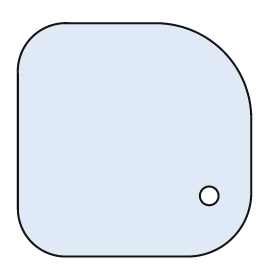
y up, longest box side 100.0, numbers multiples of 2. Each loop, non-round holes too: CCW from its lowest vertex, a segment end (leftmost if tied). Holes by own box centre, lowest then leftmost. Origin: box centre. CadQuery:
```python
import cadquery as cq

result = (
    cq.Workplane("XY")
    .moveTo(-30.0, -50.0)
    .lineTo(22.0, -50.0)
    .threePointArc((42.0, -42.0), (50.0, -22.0))
    .lineTo(50.0, 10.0)
    .threePointArc((38.0, 38.0), (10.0, 50.0))
    .lineTo(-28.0, 50.0)
    .threePointArc((-44.0, 44.0), (-50.0, 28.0))
    .lineTo(-50.0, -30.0)
    .threePointArc((-44.0, -44.0), (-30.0, -50.0))
    .close()
    .moveTo(32.0, -24.0)
    .circle(4.0)
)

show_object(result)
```